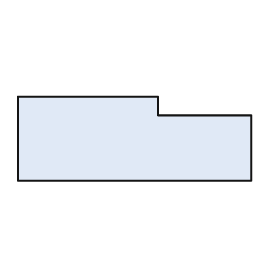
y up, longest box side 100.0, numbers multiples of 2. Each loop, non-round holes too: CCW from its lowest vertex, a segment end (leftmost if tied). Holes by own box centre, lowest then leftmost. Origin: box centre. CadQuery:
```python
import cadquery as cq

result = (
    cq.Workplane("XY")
    .moveTo(-50.0, -18.0)
    .lineTo(50.0, -18.0)
    .lineTo(50.0, 10.0)
    .lineTo(10.0, 10.0)
    .lineTo(10.0, 18.0)
    .lineTo(-50.0, 18.0)
    .close()
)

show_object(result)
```